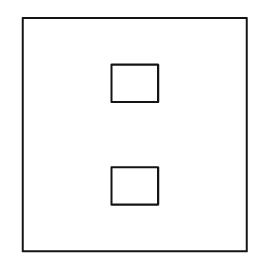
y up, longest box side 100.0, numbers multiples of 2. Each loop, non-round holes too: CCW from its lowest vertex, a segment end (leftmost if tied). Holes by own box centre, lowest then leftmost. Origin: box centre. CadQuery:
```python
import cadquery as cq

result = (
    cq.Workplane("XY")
    .moveTo(-48.0, -50.0)
    .lineTo(48.0, -50.0)
    .lineTo(48.0, 50.0)
    .lineTo(-48.0, 50.0)
    .close()
    .moveTo(-10.0, -30.0)
    .lineTo(10.0, -30.0)
    .lineTo(10.0, -14.0)
    .lineTo(-10.0, -14.0)
    .close()
    .moveTo(-10.0, 14.0)
    .lineTo(10.0, 14.0)
    .lineTo(10.0, 30.0)
    .lineTo(-10.0, 30.0)
    .close()
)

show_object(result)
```